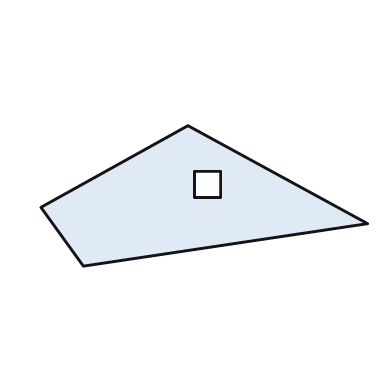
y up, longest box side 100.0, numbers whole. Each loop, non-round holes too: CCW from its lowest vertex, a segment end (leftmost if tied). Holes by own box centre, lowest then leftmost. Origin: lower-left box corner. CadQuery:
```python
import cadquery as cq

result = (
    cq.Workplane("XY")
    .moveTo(13.0, 0.0)
    .lineTo(100.0, 13.0)
    .lineTo(45.0, 43.0)
    .lineTo(0.0, 18.0)
    .close()
    .moveTo(47.0, 21.0)
    .lineTo(55.0, 21.0)
    .lineTo(55.0, 29.0)
    .lineTo(47.0, 29.0)
    .close()
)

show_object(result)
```